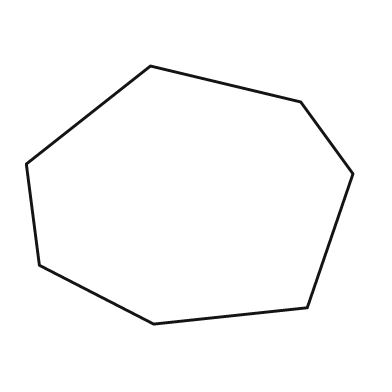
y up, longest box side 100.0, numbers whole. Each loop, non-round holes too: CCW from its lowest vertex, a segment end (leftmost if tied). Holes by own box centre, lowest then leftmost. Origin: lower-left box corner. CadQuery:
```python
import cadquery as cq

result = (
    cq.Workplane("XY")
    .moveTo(39.0, 0.0)
    .lineTo(86.0, 5.0)
    .lineTo(100.0, 46.0)
    .lineTo(84.0, 68.0)
    .lineTo(38.0, 79.0)
    .lineTo(0.0, 49.0)
    .lineTo(4.0, 18.0)
    .close()
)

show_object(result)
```